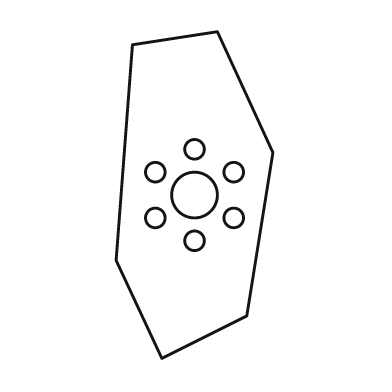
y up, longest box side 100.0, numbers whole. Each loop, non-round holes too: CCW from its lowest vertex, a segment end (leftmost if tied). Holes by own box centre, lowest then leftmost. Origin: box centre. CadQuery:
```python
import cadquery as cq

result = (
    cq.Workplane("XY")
    .moveTo(-10.0, -50.0)
    .lineTo(16.0, -37.0)
    .lineTo(24.0, 13.0)
    .lineTo(7.0, 50.0)
    .lineTo(-19.0, 46.0)
    .lineTo(-24.0, -20.0)
    .close()
    .moveTo(0.0, -14.0)
    .circle(3.0)
    .moveTo(-12.0, -7.0)
    .circle(3.0)
    .moveTo(12.0, -7.0)
    .circle(3.0)
    .moveTo(0.0, 0.0)
    .circle(7.0)
    .moveTo(-12.0, 7.0)
    .circle(3.0)
    .moveTo(12.0, 7.0)
    .circle(3.0)
    .moveTo(0.0, 14.0)
    .circle(3.0)
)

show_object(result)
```